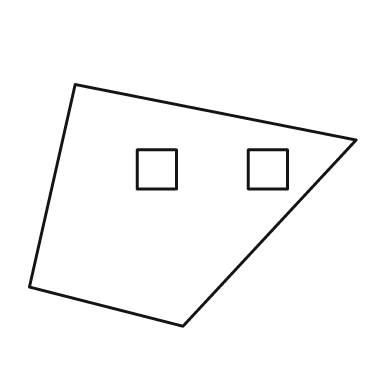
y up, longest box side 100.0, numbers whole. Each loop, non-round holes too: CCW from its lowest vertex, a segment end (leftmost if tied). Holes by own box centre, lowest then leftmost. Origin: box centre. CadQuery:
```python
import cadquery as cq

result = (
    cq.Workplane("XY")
    .moveTo(-3.0, -37.0)
    .lineTo(50.0, 20.0)
    .lineTo(-36.0, 37.0)
    .lineTo(-50.0, -25.0)
    .close()
    .moveTo(-17.0, 5.0)
    .lineTo(-5.0, 5.0)
    .lineTo(-5.0, 17.0)
    .lineTo(-17.0, 17.0)
    .close()
    .moveTo(17.0, 5.0)
    .lineTo(29.0, 5.0)
    .lineTo(29.0, 17.0)
    .lineTo(17.0, 17.0)
    .close()
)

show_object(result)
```